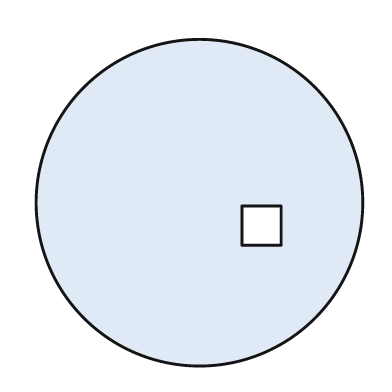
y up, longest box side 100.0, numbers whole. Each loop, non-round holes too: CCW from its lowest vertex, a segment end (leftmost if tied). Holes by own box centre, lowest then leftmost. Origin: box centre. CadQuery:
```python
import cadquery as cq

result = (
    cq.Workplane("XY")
    .moveTo(0.0, 0.0)
    .circle(50.0)
    .moveTo(13.0, -13.0)
    .lineTo(25.0, -13.0)
    .lineTo(25.0, -1.0)
    .lineTo(13.0, -1.0)
    .close()
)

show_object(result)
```